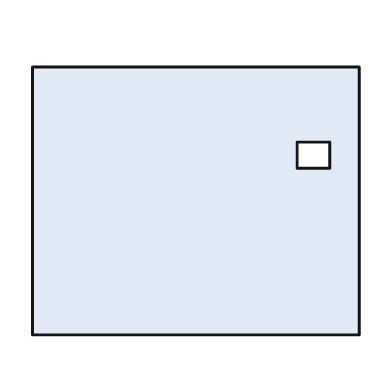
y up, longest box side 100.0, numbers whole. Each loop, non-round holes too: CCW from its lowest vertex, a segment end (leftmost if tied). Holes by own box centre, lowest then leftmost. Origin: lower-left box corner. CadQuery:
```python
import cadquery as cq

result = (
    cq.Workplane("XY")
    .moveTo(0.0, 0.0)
    .lineTo(100.0, 0.0)
    .lineTo(100.0, 82.0)
    .lineTo(0.0, 82.0)
    .close()
    .moveTo(81.0, 51.0)
    .lineTo(91.0, 51.0)
    .lineTo(91.0, 59.0)
    .lineTo(81.0, 59.0)
    .close()
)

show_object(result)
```